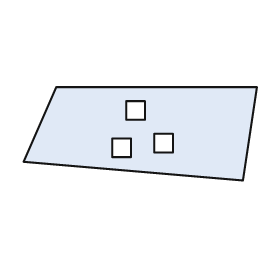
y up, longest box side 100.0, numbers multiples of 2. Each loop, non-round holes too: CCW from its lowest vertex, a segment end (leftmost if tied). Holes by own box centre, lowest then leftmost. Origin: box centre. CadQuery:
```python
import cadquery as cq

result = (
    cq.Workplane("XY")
    .moveTo(44.0, -20.0)
    .lineTo(50.0, 20.0)
    .lineTo(-36.0, 20.0)
    .lineTo(-50.0, -12.0)
    .close()
    .moveTo(-12.0, -10.0)
    .lineTo(-4.0, -10.0)
    .lineTo(-4.0, -2.0)
    .lineTo(-12.0, -2.0)
    .close()
    .moveTo(6.0, -8.0)
    .lineTo(14.0, -8.0)
    .lineTo(14.0, 0.0)
    .lineTo(6.0, 0.0)
    .close()
    .moveTo(-6.0, 6.0)
    .lineTo(2.0, 6.0)
    .lineTo(2.0, 14.0)
    .lineTo(-6.0, 14.0)
    .close()
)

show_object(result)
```